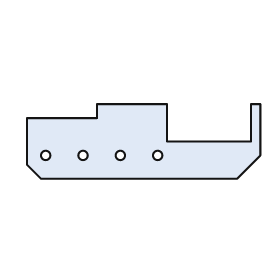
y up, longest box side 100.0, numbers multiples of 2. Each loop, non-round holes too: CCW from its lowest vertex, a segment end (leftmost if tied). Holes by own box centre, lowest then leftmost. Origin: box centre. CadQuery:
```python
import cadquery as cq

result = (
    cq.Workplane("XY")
    .moveTo(-44.0, -16.0)
    .lineTo(40.0, -16.0)
    .lineTo(50.0, -6.0)
    .lineTo(50.0, 16.0)
    .lineTo(46.0, 16.0)
    .lineTo(46.0, 0.0)
    .lineTo(10.0, 0.0)
    .lineTo(10.0, 16.0)
    .lineTo(-20.0, 16.0)
    .lineTo(-20.0, 10.0)
    .lineTo(-50.0, 10.0)
    .lineTo(-50.0, -10.0)
    .close()
    .moveTo(-42.0, -6.0)
    .circle(2.0)
    .moveTo(-26.0, -6.0)
    .circle(2.0)
    .moveTo(-10.0, -6.0)
    .circle(2.0)
    .moveTo(6.0, -6.0)
    .circle(2.0)
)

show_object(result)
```